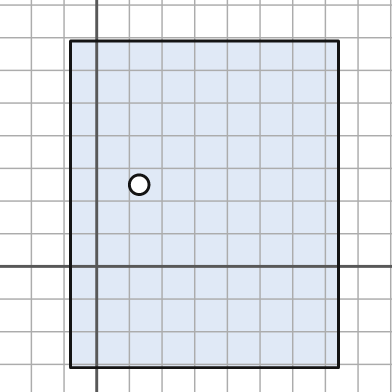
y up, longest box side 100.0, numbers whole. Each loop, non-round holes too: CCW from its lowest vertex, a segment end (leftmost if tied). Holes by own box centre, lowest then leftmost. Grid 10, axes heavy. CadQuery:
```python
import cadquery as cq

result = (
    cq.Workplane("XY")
    .moveTo(-8.0, -31.0)
    .lineTo(74.0, -31.0)
    .lineTo(74.0, 69.0)
    .lineTo(-8.0, 69.0)
    .close()
    .moveTo(13.0, 25.0)
    .circle(3.0)
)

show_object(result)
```